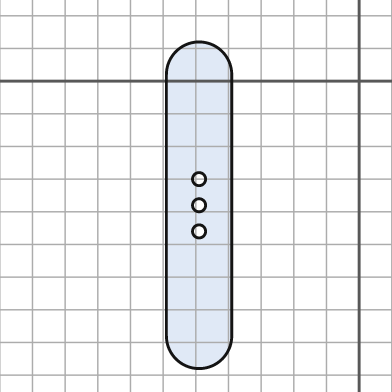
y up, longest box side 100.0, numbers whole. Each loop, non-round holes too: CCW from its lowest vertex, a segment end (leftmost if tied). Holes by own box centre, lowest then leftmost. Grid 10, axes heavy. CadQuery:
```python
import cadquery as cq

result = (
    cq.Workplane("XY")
    .moveTo(-59.0, -78.0)
    .threePointArc((-49.0, -88.0), (-39.0, -78.0))
    .lineTo(-39.0, 2.0)
    .threePointArc((-49.0, 12.0), (-59.0, 2.0))
    .close()
    .moveTo(-49.0, -46.0)
    .circle(2.0)
    .moveTo(-49.0, -38.0)
    .circle(2.0)
    .moveTo(-49.0, -30.0)
    .circle(2.0)
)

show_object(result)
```